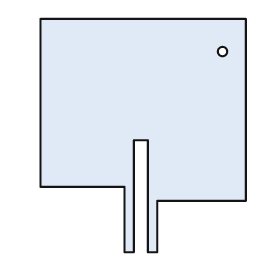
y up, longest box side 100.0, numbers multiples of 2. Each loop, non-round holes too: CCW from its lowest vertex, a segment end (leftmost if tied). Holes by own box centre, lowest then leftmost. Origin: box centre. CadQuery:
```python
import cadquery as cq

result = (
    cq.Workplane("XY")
    .moveTo(-8.0, -50.0)
    .lineTo(-4.0, -50.0)
    .lineTo(-4.0, -2.0)
    .lineTo(2.0, -2.0)
    .lineTo(2.0, -50.0)
    .lineTo(6.0, -50.0)
    .lineTo(6.0, -28.0)
    .lineTo(44.0, -28.0)
    .lineTo(44.0, 50.0)
    .lineTo(-44.0, 50.0)
    .lineTo(-44.0, -22.0)
    .lineTo(-8.0, -22.0)
    .close()
    .moveTo(34.0, 36.0)
    .circle(2.0)
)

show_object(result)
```